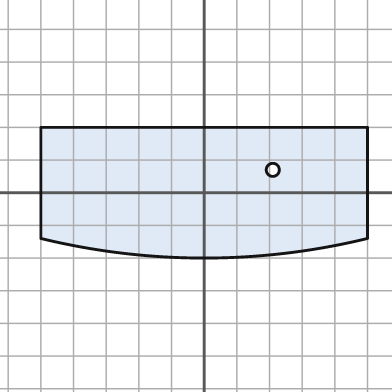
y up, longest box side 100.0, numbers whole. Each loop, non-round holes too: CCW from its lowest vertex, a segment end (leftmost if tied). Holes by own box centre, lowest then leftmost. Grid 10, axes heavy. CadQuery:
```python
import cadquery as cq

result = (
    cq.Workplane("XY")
    .moveTo(-50.0, -14.0)
    .threePointArc((0.0, -20.0), (50.0, -14.0))
    .lineTo(50.0, 20.0)
    .lineTo(-50.0, 20.0)
    .close()
    .moveTo(21.0, 7.0)
    .circle(2.0)
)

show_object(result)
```